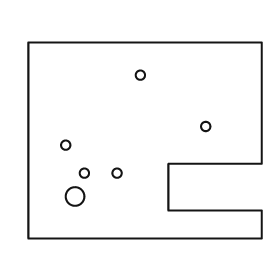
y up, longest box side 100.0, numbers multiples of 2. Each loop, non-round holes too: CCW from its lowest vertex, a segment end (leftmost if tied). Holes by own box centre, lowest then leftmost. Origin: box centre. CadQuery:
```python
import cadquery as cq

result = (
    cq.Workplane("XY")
    .moveTo(-50.0, -42.0)
    .lineTo(50.0, -42.0)
    .lineTo(50.0, -30.0)
    .lineTo(10.0, -30.0)
    .lineTo(10.0, -10.0)
    .lineTo(50.0, -10.0)
    .lineTo(50.0, 42.0)
    .lineTo(-50.0, 42.0)
    .close()
    .moveTo(-30.0, -24.0)
    .circle(4.0)
    .moveTo(-26.0, -14.0)
    .circle(2.0)
    .moveTo(-12.0, -14.0)
    .circle(2.0)
    .moveTo(-34.0, -2.0)
    .circle(2.0)
    .moveTo(26.0, 6.0)
    .circle(2.0)
    .moveTo(-2.0, 28.0)
    .circle(2.0)
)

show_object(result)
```